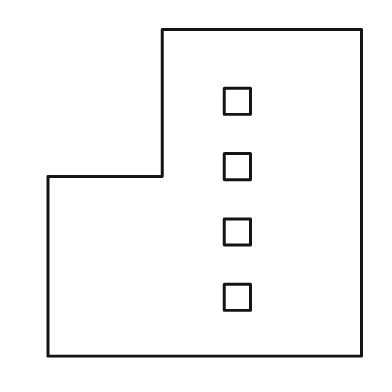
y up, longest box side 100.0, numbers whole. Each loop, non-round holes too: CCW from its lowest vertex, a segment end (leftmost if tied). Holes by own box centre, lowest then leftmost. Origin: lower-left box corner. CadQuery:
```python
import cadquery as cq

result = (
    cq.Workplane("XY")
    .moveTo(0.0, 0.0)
    .lineTo(96.0, 0.0)
    .lineTo(96.0, 100.0)
    .lineTo(35.0, 100.0)
    .lineTo(35.0, 55.0)
    .lineTo(0.0, 55.0)
    .close()
    .moveTo(54.0, 14.0)
    .lineTo(62.0, 14.0)
    .lineTo(62.0, 22.0)
    .lineTo(54.0, 22.0)
    .close()
    .moveTo(54.0, 34.0)
    .lineTo(62.0, 34.0)
    .lineTo(62.0, 42.0)
    .lineTo(54.0, 42.0)
    .close()
    .moveTo(54.0, 54.0)
    .lineTo(62.0, 54.0)
    .lineTo(62.0, 62.0)
    .lineTo(54.0, 62.0)
    .close()
    .moveTo(54.0, 74.0)
    .lineTo(62.0, 74.0)
    .lineTo(62.0, 82.0)
    .lineTo(54.0, 82.0)
    .close()
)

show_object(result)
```